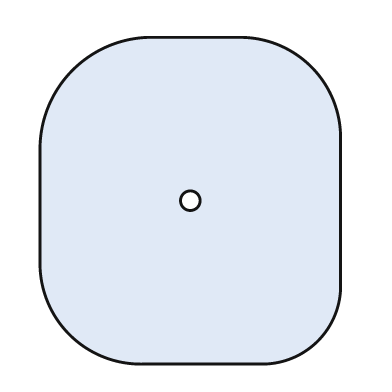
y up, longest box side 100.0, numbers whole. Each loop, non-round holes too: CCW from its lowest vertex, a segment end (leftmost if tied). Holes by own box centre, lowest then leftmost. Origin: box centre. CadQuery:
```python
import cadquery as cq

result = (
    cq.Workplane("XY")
    .moveTo(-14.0, -50.0)
    .lineTo(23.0, -50.0)
    .threePointArc((39.0, -43.0), (46.0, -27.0))
    .lineTo(46.0, 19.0)
    .threePointArc((37.0, 41.0), (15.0, 50.0))
    .lineTo(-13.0, 50.0)
    .threePointArc((-36.0, 40.0), (-46.0, 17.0))
    .lineTo(-46.0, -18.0)
    .threePointArc((-37.0, -41.0), (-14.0, -50.0))
    .close()
    .moveTo(0.0, 0.0)
    .circle(3.0)
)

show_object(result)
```